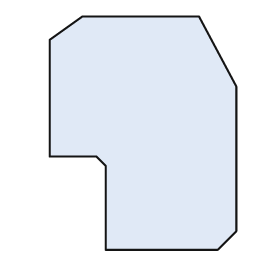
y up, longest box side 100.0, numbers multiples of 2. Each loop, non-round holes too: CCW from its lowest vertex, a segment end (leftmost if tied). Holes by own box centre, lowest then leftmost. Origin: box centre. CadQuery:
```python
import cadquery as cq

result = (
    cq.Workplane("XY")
    .moveTo(-16.0, -50.0)
    .lineTo(32.0, -50.0)
    .lineTo(40.0, -42.0)
    .lineTo(40.0, 20.0)
    .lineTo(24.0, 50.0)
    .lineTo(-26.0, 50.0)
    .lineTo(-40.0, 40.0)
    .lineTo(-40.0, -10.0)
    .lineTo(-20.0, -10.0)
    .lineTo(-16.0, -14.0)
    .close()
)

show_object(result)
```